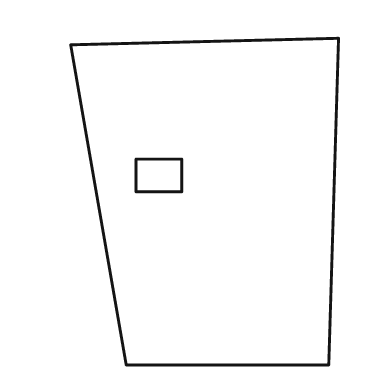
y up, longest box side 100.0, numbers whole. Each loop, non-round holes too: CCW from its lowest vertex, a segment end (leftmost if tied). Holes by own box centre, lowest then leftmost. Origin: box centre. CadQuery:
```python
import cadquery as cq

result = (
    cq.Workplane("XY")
    .moveTo(-24.0, -50.0)
    .lineTo(38.0, -50.0)
    .lineTo(41.0, 50.0)
    .lineTo(-41.0, 48.0)
    .close()
    .moveTo(-21.0, 3.0)
    .lineTo(-7.0, 3.0)
    .lineTo(-7.0, 13.0)
    .lineTo(-21.0, 13.0)
    .close()
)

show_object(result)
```